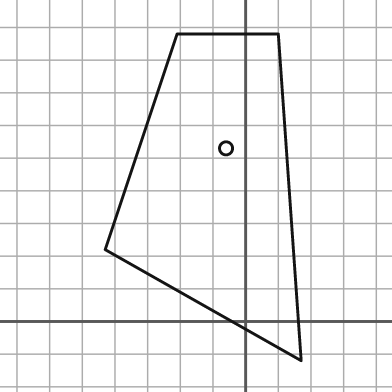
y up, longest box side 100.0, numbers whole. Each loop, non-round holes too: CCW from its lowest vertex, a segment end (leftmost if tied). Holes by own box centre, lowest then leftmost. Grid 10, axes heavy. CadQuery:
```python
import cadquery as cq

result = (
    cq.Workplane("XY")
    .moveTo(17.0, -12.0)
    .lineTo(10.0, 88.0)
    .lineTo(-21.0, 88.0)
    .lineTo(-43.0, 22.0)
    .close()
    .moveTo(-6.0, 53.0)
    .circle(2.0)
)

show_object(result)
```